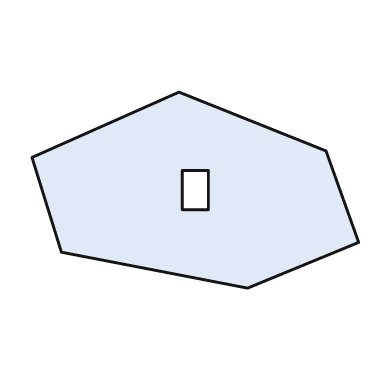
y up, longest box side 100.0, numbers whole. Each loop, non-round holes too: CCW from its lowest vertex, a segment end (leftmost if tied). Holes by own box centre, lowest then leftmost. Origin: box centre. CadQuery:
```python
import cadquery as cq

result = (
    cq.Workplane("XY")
    .moveTo(16.0, -30.0)
    .lineTo(50.0, -16.0)
    .lineTo(40.0, 12.0)
    .lineTo(-5.0, 30.0)
    .lineTo(-50.0, 10.0)
    .lineTo(-41.0, -19.0)
    .close()
    .moveTo(-4.0, -6.0)
    .lineTo(4.0, -6.0)
    .lineTo(4.0, 6.0)
    .lineTo(-4.0, 6.0)
    .close()
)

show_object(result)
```